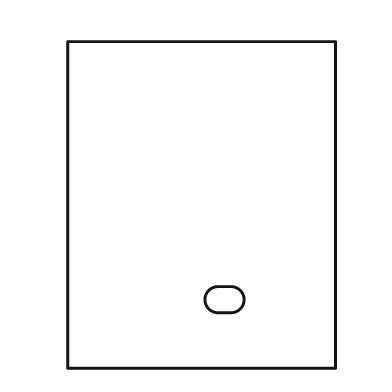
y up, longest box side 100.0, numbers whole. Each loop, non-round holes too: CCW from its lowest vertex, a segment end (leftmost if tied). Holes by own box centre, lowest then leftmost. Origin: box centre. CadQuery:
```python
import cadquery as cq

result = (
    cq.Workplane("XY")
    .moveTo(-41.0, -50.0)
    .lineTo(41.0, -50.0)
    .lineTo(41.0, 50.0)
    .lineTo(-41.0, 50.0)
    .close()
    .moveTo(5.0, -33.0)
    .lineTo(9.0, -33.0)
    .threePointArc((13.0, -29.0), (9.0, -25.0))
    .lineTo(5.0, -25.0)
    .threePointArc((1.0, -29.0), (5.0, -33.0))
    .close()
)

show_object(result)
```